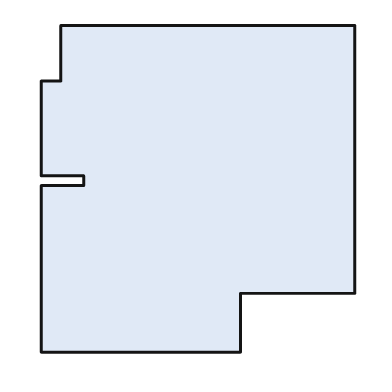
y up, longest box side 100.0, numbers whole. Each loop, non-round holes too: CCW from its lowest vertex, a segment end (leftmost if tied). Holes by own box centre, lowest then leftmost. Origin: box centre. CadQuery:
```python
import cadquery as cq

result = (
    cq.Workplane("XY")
    .moveTo(-48.0, -50.0)
    .lineTo(13.0, -50.0)
    .lineTo(13.0, -32.0)
    .lineTo(48.0, -32.0)
    .lineTo(48.0, 50.0)
    .lineTo(-42.0, 50.0)
    .lineTo(-42.0, 33.0)
    .lineTo(-48.0, 33.0)
    .lineTo(-48.0, 4.0)
    .lineTo(-35.0, 4.0)
    .lineTo(-35.0, 1.0)
    .lineTo(-48.0, 1.0)
    .close()
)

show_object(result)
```